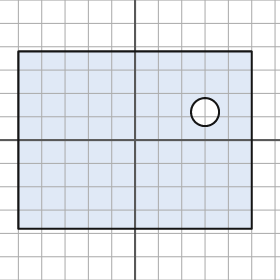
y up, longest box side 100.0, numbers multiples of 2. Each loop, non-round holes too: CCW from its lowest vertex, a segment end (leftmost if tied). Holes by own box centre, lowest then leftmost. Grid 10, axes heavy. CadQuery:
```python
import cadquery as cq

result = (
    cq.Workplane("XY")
    .moveTo(-50.0, -38.0)
    .lineTo(50.0, -38.0)
    .lineTo(50.0, 38.0)
    .lineTo(-50.0, 38.0)
    .close()
    .moveTo(30.0, 12.0)
    .circle(6.0)
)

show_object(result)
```